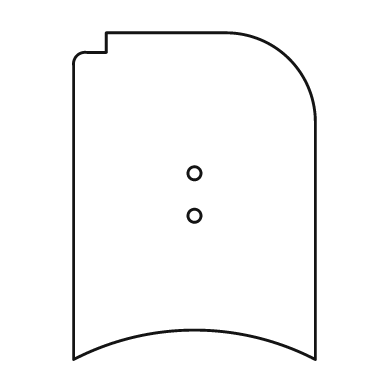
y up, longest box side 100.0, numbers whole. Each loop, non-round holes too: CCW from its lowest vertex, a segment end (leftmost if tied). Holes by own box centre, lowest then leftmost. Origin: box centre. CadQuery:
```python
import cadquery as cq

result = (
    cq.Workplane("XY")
    .moveTo(-37.0, -50.0)
    .threePointArc((0.0, -41.0), (37.0, -50.0))
    .lineTo(37.0, 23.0)
    .threePointArc((29.0, 42.0), (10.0, 50.0))
    .lineTo(-27.0, 50.0)
    .lineTo(-27.0, 44.0)
    .lineTo(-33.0, 44.0)
    .threePointArc((-36.0, 43.0), (-37.0, 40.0))
    .close()
    .moveTo(0.0, -6.0)
    .circle(2.0)
    .moveTo(0.0, 7.0)
    .circle(2.0)
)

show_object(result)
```